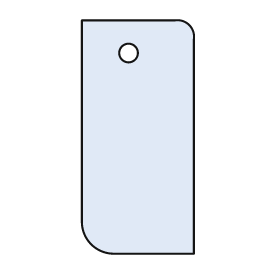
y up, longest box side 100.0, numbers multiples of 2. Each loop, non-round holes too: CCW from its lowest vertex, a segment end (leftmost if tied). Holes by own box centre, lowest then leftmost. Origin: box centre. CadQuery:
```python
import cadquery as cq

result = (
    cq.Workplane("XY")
    .moveTo(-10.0, -50.0)
    .lineTo(24.0, -50.0)
    .lineTo(24.0, 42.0)
    .threePointArc((22.0, 48.0), (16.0, 50.0))
    .lineTo(-24.0, 50.0)
    .lineTo(-24.0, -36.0)
    .threePointArc((-20.0, -46.0), (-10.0, -50.0))
    .close()
    .moveTo(-4.0, 36.0)
    .circle(4.0)
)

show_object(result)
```